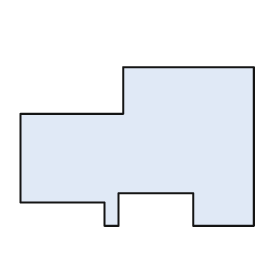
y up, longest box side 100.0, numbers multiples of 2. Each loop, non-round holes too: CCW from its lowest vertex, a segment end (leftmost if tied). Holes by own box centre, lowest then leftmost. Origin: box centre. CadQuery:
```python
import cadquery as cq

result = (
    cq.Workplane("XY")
    .moveTo(-14.0, -34.0)
    .lineTo(-8.0, -34.0)
    .lineTo(-8.0, -20.0)
    .lineTo(24.0, -20.0)
    .lineTo(24.0, -34.0)
    .lineTo(50.0, -34.0)
    .lineTo(50.0, 34.0)
    .lineTo(-6.0, 34.0)
    .lineTo(-6.0, 14.0)
    .lineTo(-50.0, 14.0)
    .lineTo(-50.0, -24.0)
    .lineTo(-14.0, -24.0)
    .close()
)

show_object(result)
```